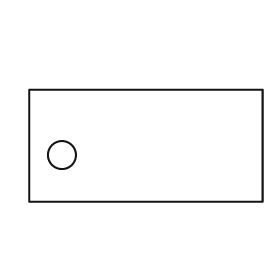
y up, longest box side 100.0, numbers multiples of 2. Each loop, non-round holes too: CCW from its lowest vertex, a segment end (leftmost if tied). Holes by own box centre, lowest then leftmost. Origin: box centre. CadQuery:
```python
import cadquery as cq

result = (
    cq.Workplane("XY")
    .moveTo(-50.0, -24.0)
    .lineTo(50.0, -24.0)
    .lineTo(50.0, 24.0)
    .lineTo(-50.0, 24.0)
    .close()
    .moveTo(-36.0, -4.0)
    .circle(6.0)
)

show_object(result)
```